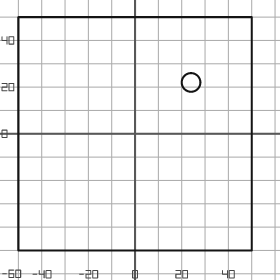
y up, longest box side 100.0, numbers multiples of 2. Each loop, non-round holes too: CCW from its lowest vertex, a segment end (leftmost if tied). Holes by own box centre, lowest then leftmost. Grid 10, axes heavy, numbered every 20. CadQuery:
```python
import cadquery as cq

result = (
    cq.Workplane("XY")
    .moveTo(-50.0, -50.0)
    .lineTo(50.0, -50.0)
    .lineTo(50.0, 50.0)
    .lineTo(-50.0, 50.0)
    .close()
    .moveTo(24.0, 22.0)
    .circle(4.0)
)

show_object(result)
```